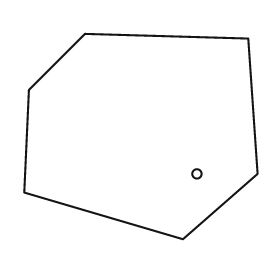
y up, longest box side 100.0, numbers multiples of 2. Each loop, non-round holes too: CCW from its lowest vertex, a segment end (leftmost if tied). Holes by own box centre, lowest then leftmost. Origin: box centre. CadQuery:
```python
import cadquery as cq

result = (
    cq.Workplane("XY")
    .moveTo(18.0, -44.0)
    .lineTo(50.0, -16.0)
    .lineTo(46.0, 42.0)
    .lineTo(-24.0, 44.0)
    .lineTo(-48.0, 20.0)
    .lineTo(-50.0, -24.0)
    .close()
    .moveTo(24.0, -16.0)
    .circle(2.0)
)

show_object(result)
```